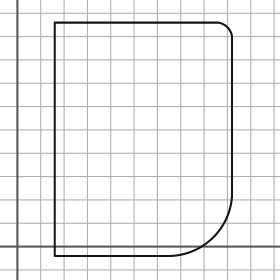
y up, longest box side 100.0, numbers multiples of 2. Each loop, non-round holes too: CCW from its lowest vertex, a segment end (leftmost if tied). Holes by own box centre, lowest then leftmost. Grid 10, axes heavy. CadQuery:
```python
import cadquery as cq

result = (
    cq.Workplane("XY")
    .moveTo(16.0, -4.0)
    .lineTo(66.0, -4.0)
    .threePointArc((84.0, 4.0), (92.0, 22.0))
    .lineTo(92.0, 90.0)
    .threePointArc((90.0, 94.0), (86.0, 96.0))
    .lineTo(16.0, 96.0)
    .close()
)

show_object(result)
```